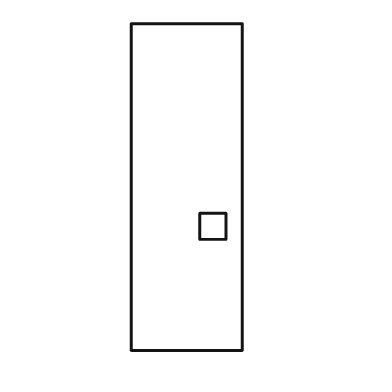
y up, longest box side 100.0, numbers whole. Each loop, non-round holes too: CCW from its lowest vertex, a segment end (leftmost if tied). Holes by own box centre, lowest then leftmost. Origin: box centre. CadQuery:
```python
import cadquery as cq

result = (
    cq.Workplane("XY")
    .moveTo(-17.0, -50.0)
    .lineTo(17.0, -50.0)
    .lineTo(17.0, 50.0)
    .lineTo(-17.0, 50.0)
    .close()
    .moveTo(4.0, -16.0)
    .lineTo(12.0, -16.0)
    .lineTo(12.0, -8.0)
    .lineTo(4.0, -8.0)
    .close()
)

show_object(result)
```